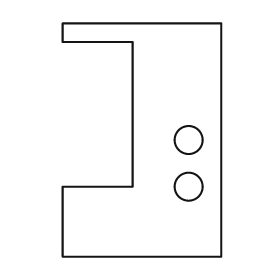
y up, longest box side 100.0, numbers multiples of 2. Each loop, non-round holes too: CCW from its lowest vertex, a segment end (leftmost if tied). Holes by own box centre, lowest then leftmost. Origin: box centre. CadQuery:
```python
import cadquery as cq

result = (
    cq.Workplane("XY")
    .moveTo(-34.0, -50.0)
    .lineTo(34.0, -50.0)
    .lineTo(34.0, 50.0)
    .lineTo(-34.0, 50.0)
    .lineTo(-34.0, 42.0)
    .lineTo(-4.0, 42.0)
    .lineTo(-4.0, -20.0)
    .lineTo(-34.0, -20.0)
    .close()
    .moveTo(20.0, -20.0)
    .circle(6.0)
    .moveTo(20.0, 0.0)
    .circle(6.0)
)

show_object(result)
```